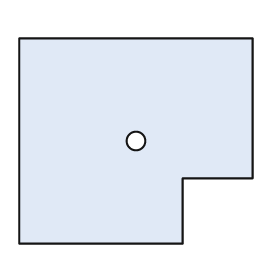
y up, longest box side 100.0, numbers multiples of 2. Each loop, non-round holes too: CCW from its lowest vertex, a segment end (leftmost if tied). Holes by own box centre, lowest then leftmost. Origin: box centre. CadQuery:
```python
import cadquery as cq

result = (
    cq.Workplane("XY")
    .moveTo(-50.0, -44.0)
    .lineTo(20.0, -44.0)
    .lineTo(20.0, -16.0)
    .lineTo(50.0, -16.0)
    .lineTo(50.0, 44.0)
    .lineTo(-50.0, 44.0)
    .close()
    .moveTo(0.0, 0.0)
    .circle(4.0)
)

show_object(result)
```